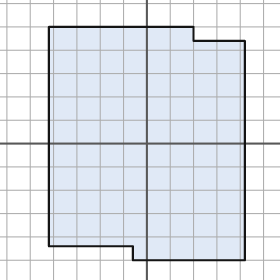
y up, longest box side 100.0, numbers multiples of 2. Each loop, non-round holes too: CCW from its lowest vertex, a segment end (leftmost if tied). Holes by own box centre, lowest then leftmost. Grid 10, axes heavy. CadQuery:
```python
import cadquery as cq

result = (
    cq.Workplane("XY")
    .moveTo(-6.0, -50.0)
    .lineTo(42.0, -50.0)
    .lineTo(42.0, 44.0)
    .lineTo(20.0, 44.0)
    .lineTo(20.0, 50.0)
    .lineTo(-42.0, 50.0)
    .lineTo(-42.0, -44.0)
    .lineTo(-6.0, -44.0)
    .close()
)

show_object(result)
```